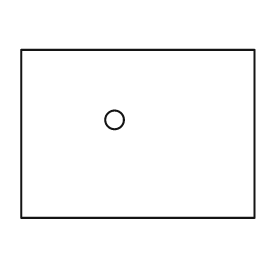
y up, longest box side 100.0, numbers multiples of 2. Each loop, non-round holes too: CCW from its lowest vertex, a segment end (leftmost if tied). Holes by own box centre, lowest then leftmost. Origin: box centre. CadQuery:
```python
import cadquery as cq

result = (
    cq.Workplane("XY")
    .moveTo(-50.0, -36.0)
    .lineTo(50.0, -36.0)
    .lineTo(50.0, 36.0)
    .lineTo(-50.0, 36.0)
    .close()
    .moveTo(-10.0, 6.0)
    .circle(4.0)
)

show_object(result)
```